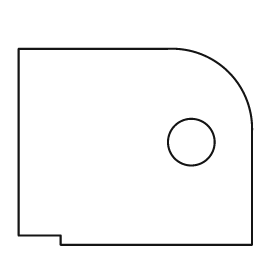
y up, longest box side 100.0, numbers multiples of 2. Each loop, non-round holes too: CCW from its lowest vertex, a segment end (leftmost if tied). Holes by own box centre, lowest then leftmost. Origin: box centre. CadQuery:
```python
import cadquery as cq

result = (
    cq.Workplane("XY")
    .moveTo(-32.0, -42.0)
    .lineTo(50.0, -42.0)
    .lineTo(50.0, 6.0)
    .threePointArc((40.0, 32.0), (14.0, 42.0))
    .lineTo(-50.0, 42.0)
    .lineTo(-50.0, -38.0)
    .lineTo(-32.0, -38.0)
    .close()
    .moveTo(24.0, 2.0)
    .circle(10.0)
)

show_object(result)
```